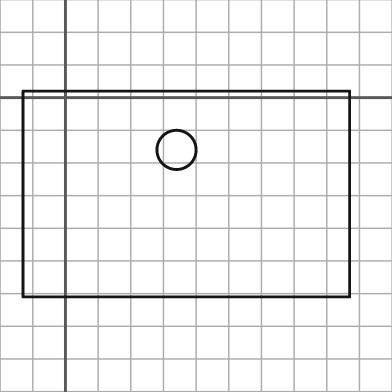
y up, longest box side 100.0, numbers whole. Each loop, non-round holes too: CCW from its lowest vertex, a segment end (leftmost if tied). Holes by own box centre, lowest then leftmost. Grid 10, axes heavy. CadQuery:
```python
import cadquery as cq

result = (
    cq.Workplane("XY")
    .moveTo(-13.0, -61.0)
    .lineTo(87.0, -61.0)
    .lineTo(87.0, 2.0)
    .lineTo(-13.0, 2.0)
    .close()
    .moveTo(34.0, -16.0)
    .circle(6.0)
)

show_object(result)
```